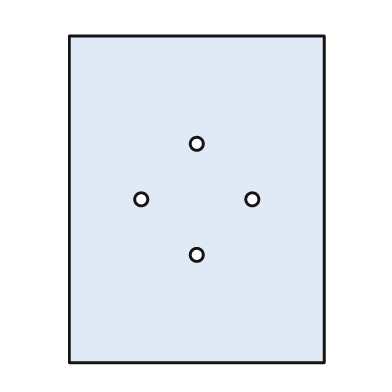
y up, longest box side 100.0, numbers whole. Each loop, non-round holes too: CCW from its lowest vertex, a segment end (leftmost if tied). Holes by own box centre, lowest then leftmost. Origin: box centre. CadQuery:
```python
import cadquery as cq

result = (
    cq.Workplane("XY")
    .moveTo(-39.0, -50.0)
    .lineTo(39.0, -50.0)
    .lineTo(39.0, 50.0)
    .lineTo(-39.0, 50.0)
    .close()
    .moveTo(0.0, -17.0)
    .circle(2.0)
    .moveTo(-17.0, 0.0)
    .circle(2.0)
    .moveTo(17.0, 0.0)
    .circle(2.0)
    .moveTo(0.0, 17.0)
    .circle(2.0)
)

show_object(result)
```